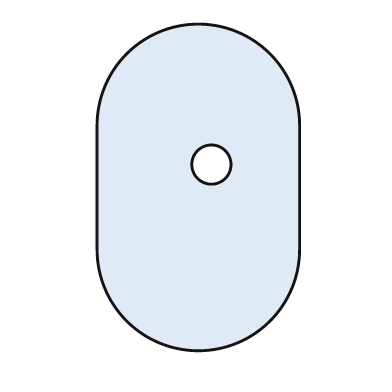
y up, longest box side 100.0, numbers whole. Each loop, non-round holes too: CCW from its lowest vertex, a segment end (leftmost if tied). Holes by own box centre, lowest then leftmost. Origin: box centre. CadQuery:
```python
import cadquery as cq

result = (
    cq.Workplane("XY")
    .moveTo(-31.0, -19.0)
    .threePointArc((0.0, -50.0), (31.0, -19.0))
    .lineTo(31.0, 19.0)
    .threePointArc((0.0, 50.0), (-31.0, 19.0))
    .close()
    .moveTo(4.0, 7.0)
    .circle(6.0)
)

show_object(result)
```